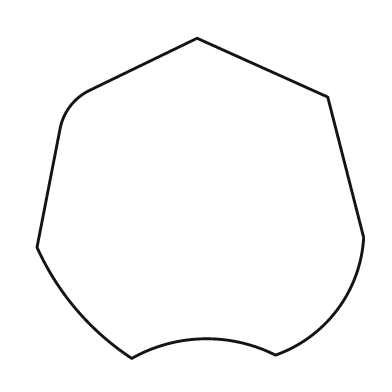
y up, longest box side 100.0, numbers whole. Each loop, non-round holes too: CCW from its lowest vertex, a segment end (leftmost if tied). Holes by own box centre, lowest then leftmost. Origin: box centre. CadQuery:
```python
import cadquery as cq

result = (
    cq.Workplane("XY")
    .moveTo(-21.0, -49.0)
    .threePointArc((1.0, -43.0), (23.0, -48.0))
    .threePointArc((42.0, -34.0), (50.0, -12.0))
    .lineTo(39.0, 31.0)
    .lineTo(-1.0, 49.0)
    .lineTo(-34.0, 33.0)
    .threePointArc((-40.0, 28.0), (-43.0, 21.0))
    .lineTo(-50.0, -15.0)
    .threePointArc((-38.0, -34.0), (-21.0, -49.0))
    .close()
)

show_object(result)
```